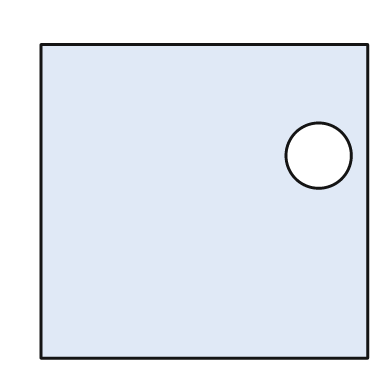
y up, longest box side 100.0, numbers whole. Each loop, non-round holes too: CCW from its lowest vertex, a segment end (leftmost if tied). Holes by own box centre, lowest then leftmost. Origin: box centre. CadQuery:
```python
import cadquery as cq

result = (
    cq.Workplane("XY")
    .moveTo(-50.0, -48.0)
    .lineTo(50.0, -48.0)
    .lineTo(50.0, 48.0)
    .lineTo(-50.0, 48.0)
    .close()
    .moveTo(35.0, 14.0)
    .circle(10.0)
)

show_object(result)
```